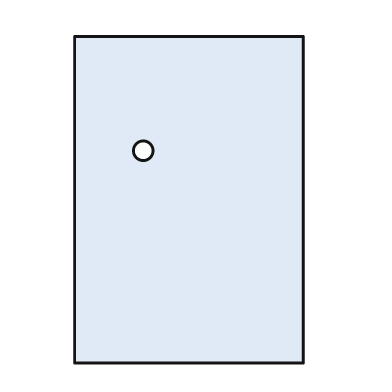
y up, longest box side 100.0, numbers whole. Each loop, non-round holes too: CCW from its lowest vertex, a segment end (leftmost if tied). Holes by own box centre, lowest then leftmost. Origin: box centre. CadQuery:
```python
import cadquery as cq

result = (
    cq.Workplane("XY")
    .moveTo(-35.0, -50.0)
    .lineTo(35.0, -50.0)
    .lineTo(35.0, 50.0)
    .lineTo(-35.0, 50.0)
    .close()
    .moveTo(-14.0, 15.0)
    .circle(3.0)
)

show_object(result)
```